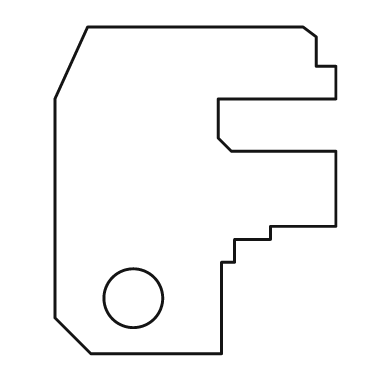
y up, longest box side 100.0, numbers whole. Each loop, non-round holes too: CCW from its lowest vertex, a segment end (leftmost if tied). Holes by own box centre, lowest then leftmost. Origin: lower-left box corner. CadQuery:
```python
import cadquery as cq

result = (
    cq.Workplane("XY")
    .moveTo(11.0, 0.0)
    .lineTo(51.0, 0.0)
    .lineTo(51.0, 28.0)
    .lineTo(55.0, 28.0)
    .lineTo(55.0, 35.0)
    .lineTo(66.0, 35.0)
    .lineTo(66.0, 39.0)
    .lineTo(86.0, 39.0)
    .lineTo(86.0, 62.0)
    .lineTo(54.0, 62.0)
    .lineTo(50.0, 66.0)
    .lineTo(50.0, 78.0)
    .lineTo(86.0, 78.0)
    .lineTo(86.0, 88.0)
    .lineTo(80.0, 88.0)
    .lineTo(80.0, 97.0)
    .lineTo(76.0, 100.0)
    .lineTo(10.0, 100.0)
    .lineTo(0.0, 78.0)
    .lineTo(0.0, 11.0)
    .close()
    .moveTo(24.0, 17.0)
    .circle(9.0)
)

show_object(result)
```